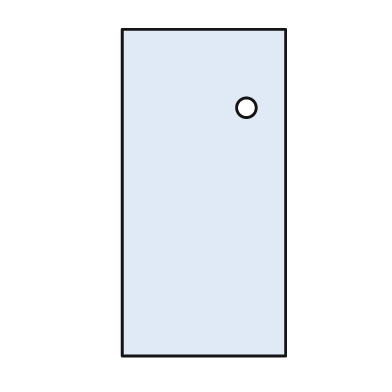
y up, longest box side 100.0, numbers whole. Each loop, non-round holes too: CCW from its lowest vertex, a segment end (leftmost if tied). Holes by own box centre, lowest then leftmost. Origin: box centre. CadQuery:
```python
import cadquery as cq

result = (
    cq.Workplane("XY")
    .moveTo(-25.0, -50.0)
    .lineTo(25.0, -50.0)
    .lineTo(25.0, 50.0)
    .lineTo(-25.0, 50.0)
    .close()
    .moveTo(13.0, 26.0)
    .circle(3.0)
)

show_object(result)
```